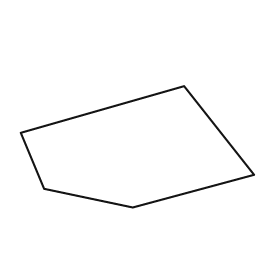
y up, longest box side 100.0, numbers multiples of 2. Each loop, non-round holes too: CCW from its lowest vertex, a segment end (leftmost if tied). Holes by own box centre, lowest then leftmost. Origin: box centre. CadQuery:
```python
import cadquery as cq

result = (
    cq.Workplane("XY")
    .moveTo(-2.0, -26.0)
    .lineTo(50.0, -12.0)
    .lineTo(20.0, 26.0)
    .lineTo(-50.0, 6.0)
    .lineTo(-40.0, -18.0)
    .close()
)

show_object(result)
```